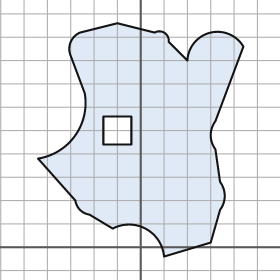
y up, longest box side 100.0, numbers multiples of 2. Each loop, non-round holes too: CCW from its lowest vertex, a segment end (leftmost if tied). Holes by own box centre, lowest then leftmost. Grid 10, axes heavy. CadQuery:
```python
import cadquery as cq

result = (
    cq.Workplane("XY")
    .moveTo(10.0, -4.0)
    .lineTo(30.0, 2.0)
    .lineTo(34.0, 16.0)
    .threePointArc((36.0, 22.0), (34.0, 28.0))
    .lineTo(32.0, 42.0)
    .threePointArc((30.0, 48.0), (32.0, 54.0))
    .lineTo(44.0, 86.0)
    .threePointArc((30.0, 92.0), (20.0, 80.0))
    .lineTo(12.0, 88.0)
    .threePointArc((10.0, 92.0), (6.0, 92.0))
    .lineTo(-10.0, 96.0)
    .lineTo(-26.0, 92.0)
    .threePointArc((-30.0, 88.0), (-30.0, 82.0))
    .lineTo(-24.0, 66.0)
    .threePointArc((-28.0, 48.0), (-44.0, 38.0))
    .lineTo(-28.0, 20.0)
    .threePointArc((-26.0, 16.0), (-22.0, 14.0))
    .lineTo(-12.0, 8.0)
    .threePointArc((2.0, 8.0), (10.0, -4.0))
    .close()
    .moveTo(-16.0, 44.0)
    .lineTo(-4.0, 44.0)
    .lineTo(-4.0, 56.0)
    .lineTo(-16.0, 56.0)
    .close()
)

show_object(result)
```